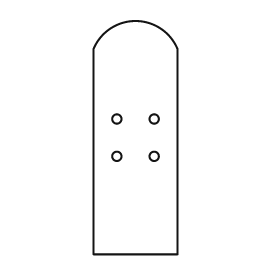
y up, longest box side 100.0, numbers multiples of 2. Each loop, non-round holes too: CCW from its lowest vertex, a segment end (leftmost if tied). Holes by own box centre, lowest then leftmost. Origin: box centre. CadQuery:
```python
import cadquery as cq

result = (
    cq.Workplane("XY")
    .moveTo(-18.0, -50.0)
    .lineTo(18.0, -50.0)
    .lineTo(18.0, 38.0)
    .threePointArc((0.0, 50.0), (-18.0, 38.0))
    .close()
    .moveTo(-8.0, -8.0)
    .circle(2.0)
    .moveTo(8.0, -8.0)
    .circle(2.0)
    .moveTo(-8.0, 8.0)
    .circle(2.0)
    .moveTo(8.0, 8.0)
    .circle(2.0)
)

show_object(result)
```